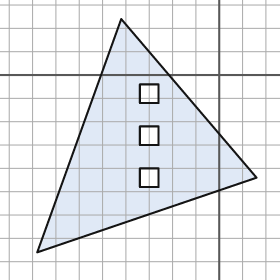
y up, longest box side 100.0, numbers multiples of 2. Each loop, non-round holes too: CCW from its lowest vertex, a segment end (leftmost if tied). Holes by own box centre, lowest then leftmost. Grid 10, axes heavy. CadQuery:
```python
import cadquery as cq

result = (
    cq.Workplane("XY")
    .moveTo(-78.0, -76.0)
    .lineTo(16.0, -44.0)
    .lineTo(-42.0, 24.0)
    .close()
    .moveTo(-34.0, -48.0)
    .lineTo(-26.0, -48.0)
    .lineTo(-26.0, -40.0)
    .lineTo(-34.0, -40.0)
    .close()
    .moveTo(-34.0, -30.0)
    .lineTo(-26.0, -30.0)
    .lineTo(-26.0, -22.0)
    .lineTo(-34.0, -22.0)
    .close()
    .moveTo(-34.0, -12.0)
    .lineTo(-26.0, -12.0)
    .lineTo(-26.0, -4.0)
    .lineTo(-34.0, -4.0)
    .close()
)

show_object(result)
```